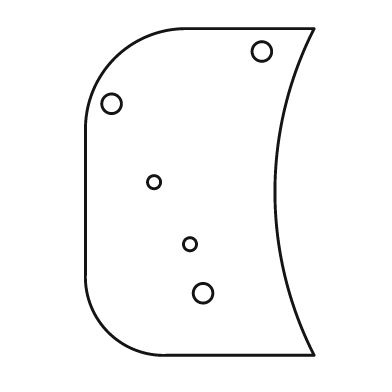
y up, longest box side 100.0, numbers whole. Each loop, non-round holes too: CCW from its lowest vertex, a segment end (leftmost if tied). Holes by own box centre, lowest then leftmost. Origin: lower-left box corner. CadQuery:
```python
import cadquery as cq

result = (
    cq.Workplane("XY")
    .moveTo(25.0, 0.0)
    .lineTo(70.0, 0.0)
    .threePointArc((58.0, 50.0), (70.0, 100.0))
    .lineTo(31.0, 100.0)
    .threePointArc((9.0, 91.0), (0.0, 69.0))
    .lineTo(0.0, 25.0)
    .threePointArc((7.0, 7.0), (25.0, 0.0))
    .close()
    .moveTo(36.0, 19.0)
    .circle(3.0)
    .moveTo(32.0, 34.0)
    .circle(2.0)
    .moveTo(21.0, 53.0)
    .circle(2.0)
    .moveTo(8.0, 77.0)
    .circle(3.0)
    .moveTo(54.0, 93.0)
    .circle(3.0)
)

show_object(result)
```